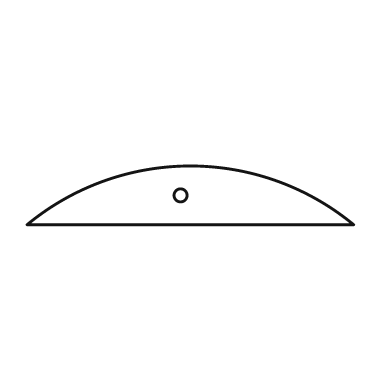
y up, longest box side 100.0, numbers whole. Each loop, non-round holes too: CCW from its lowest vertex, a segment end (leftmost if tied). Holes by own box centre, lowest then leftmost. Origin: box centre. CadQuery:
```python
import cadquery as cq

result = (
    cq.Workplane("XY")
    .moveTo(-50.0, -9.0)
    .lineTo(50.0, -9.0)
    .threePointArc((0.0, 9.0), (-50.0, -9.0))
    .close()
    .moveTo(-3.0, 0.0)
    .circle(2.0)
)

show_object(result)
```